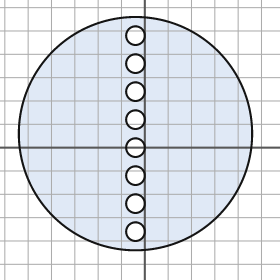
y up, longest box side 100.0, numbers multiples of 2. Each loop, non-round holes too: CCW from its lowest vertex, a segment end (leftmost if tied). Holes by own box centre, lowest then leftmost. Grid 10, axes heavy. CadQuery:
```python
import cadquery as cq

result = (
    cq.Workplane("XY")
    .moveTo(-4.0, 6.0)
    .circle(50.0)
    .moveTo(-4.0, -36.0)
    .circle(4.0)
    .moveTo(-4.0, -24.0)
    .circle(4.0)
    .moveTo(-4.0, -12.0)
    .circle(4.0)
    .moveTo(-4.0, 0.0)
    .circle(4.0)
    .moveTo(-4.0, 12.0)
    .circle(4.0)
    .moveTo(-4.0, 24.0)
    .circle(4.0)
    .moveTo(-4.0, 36.0)
    .circle(4.0)
    .moveTo(-4.0, 48.0)
    .circle(4.0)
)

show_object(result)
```